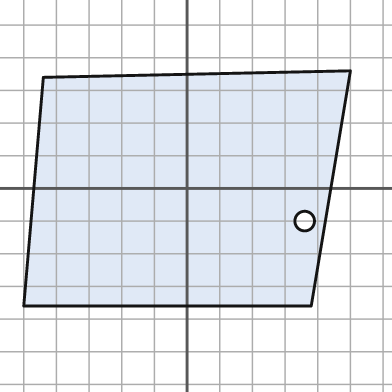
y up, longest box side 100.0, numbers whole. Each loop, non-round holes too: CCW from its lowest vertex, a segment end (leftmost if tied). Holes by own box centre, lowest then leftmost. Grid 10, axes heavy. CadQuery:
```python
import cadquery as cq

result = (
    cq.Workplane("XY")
    .moveTo(-50.0, -36.0)
    .lineTo(38.0, -36.0)
    .lineTo(50.0, 36.0)
    .lineTo(-44.0, 34.0)
    .close()
    .moveTo(36.0, -10.0)
    .circle(3.0)
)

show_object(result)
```